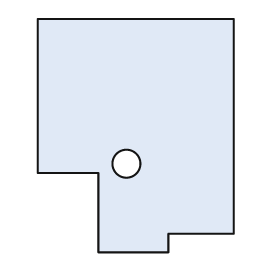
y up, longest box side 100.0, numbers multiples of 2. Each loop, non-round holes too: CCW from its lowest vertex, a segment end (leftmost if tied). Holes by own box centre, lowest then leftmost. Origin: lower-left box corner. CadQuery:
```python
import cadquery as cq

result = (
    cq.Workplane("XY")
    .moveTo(26.0, 0.0)
    .lineTo(56.0, 0.0)
    .lineTo(56.0, 8.0)
    .lineTo(84.0, 8.0)
    .lineTo(84.0, 100.0)
    .lineTo(0.0, 100.0)
    .lineTo(0.0, 34.0)
    .lineTo(26.0, 34.0)
    .close()
    .moveTo(38.0, 38.0)
    .circle(6.0)
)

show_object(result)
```